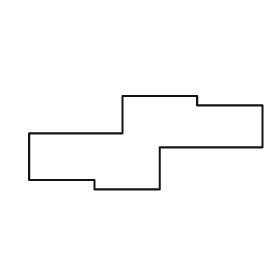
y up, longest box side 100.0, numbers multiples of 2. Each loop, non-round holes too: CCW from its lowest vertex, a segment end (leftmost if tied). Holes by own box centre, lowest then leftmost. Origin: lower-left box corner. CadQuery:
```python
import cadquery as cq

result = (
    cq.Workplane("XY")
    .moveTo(28.0, 0.0)
    .lineTo(56.0, 0.0)
    .lineTo(56.0, 18.0)
    .lineTo(100.0, 18.0)
    .lineTo(100.0, 36.0)
    .lineTo(72.0, 36.0)
    .lineTo(72.0, 40.0)
    .lineTo(40.0, 40.0)
    .lineTo(40.0, 24.0)
    .lineTo(0.0, 24.0)
    .lineTo(0.0, 4.0)
    .lineTo(28.0, 4.0)
    .close()
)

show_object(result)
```